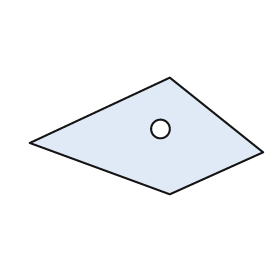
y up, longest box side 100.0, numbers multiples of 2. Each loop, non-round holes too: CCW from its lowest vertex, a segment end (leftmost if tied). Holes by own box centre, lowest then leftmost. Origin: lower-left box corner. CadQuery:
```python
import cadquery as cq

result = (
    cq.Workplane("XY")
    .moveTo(60.0, 0.0)
    .lineTo(100.0, 18.0)
    .lineTo(60.0, 50.0)
    .lineTo(0.0, 22.0)
    .close()
    .moveTo(56.0, 28.0)
    .circle(4.0)
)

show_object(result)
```